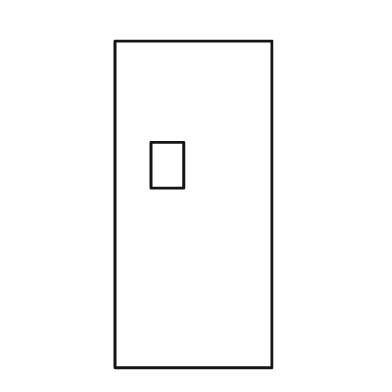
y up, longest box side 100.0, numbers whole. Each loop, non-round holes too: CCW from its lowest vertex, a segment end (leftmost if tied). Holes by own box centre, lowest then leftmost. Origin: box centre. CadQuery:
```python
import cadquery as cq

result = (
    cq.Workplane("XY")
    .moveTo(-24.0, -50.0)
    .lineTo(24.0, -50.0)
    .lineTo(24.0, 50.0)
    .lineTo(-24.0, 50.0)
    .close()
    .moveTo(-13.0, 5.0)
    .lineTo(-3.0, 5.0)
    .lineTo(-3.0, 19.0)
    .lineTo(-13.0, 19.0)
    .close()
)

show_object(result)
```